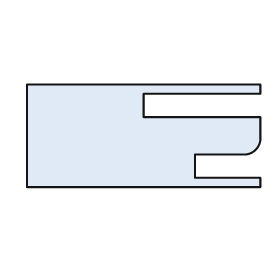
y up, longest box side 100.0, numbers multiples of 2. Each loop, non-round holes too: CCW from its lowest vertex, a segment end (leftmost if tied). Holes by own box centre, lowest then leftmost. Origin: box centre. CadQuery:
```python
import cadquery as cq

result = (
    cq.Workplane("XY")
    .moveTo(-50.0, -22.0)
    .lineTo(50.0, -22.0)
    .lineTo(50.0, -18.0)
    .lineTo(22.0, -18.0)
    .lineTo(22.0, -8.0)
    .lineTo(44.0, -8.0)
    .threePointArc((48.0, -6.0), (50.0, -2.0))
    .lineTo(50.0, 8.0)
    .lineTo(0.0, 8.0)
    .lineTo(0.0, 18.0)
    .lineTo(50.0, 18.0)
    .lineTo(50.0, 22.0)
    .lineTo(-50.0, 22.0)
    .close()
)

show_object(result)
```